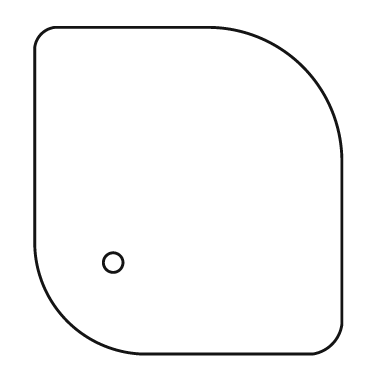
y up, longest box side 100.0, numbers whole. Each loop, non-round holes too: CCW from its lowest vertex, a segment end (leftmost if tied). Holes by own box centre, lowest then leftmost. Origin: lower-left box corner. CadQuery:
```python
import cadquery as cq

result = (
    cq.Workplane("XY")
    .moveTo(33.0, 0.0)
    .lineTo(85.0, 0.0)
    .threePointArc((91.0, 3.0), (94.0, 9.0))
    .lineTo(94.0, 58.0)
    .threePointArc((82.0, 88.0), (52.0, 100.0))
    .lineTo(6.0, 100.0)
    .threePointArc((2.0, 98.0), (0.0, 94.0))
    .lineTo(0.0, 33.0)
    .threePointArc((10.0, 10.0), (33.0, 0.0))
    .close()
    .moveTo(24.0, 28.0)
    .circle(3.0)
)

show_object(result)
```